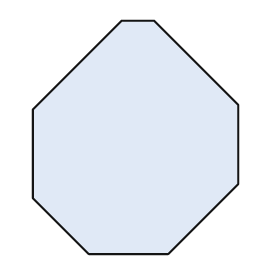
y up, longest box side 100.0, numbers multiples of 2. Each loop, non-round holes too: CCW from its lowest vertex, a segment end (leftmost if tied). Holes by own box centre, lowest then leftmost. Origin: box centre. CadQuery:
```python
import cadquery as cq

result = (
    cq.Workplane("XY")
    .moveTo(-20.0, -50.0)
    .lineTo(14.0, -50.0)
    .lineTo(44.0, -20.0)
    .lineTo(44.0, 14.0)
    .lineTo(8.0, 50.0)
    .lineTo(-6.0, 50.0)
    .lineTo(-44.0, 12.0)
    .lineTo(-44.0, -26.0)
    .close()
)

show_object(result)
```